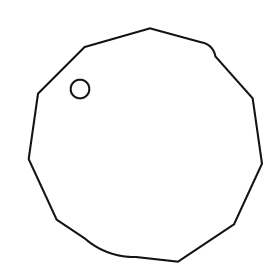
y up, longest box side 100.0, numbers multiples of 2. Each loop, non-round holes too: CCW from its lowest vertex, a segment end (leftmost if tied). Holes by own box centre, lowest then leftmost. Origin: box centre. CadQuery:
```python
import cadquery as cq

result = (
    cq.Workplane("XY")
    .moveTo(14.0, -50.0)
    .lineTo(38.0, -34.0)
    .lineTo(50.0, -8.0)
    .lineTo(46.0, 20.0)
    .lineTo(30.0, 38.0)
    .threePointArc((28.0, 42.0), (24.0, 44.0))
    .lineTo(2.0, 50.0)
    .lineTo(-26.0, 42.0)
    .lineTo(-46.0, 22.0)
    .lineTo(-50.0, -6.0)
    .lineTo(-38.0, -32.0)
    .lineTo(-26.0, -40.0)
    .threePointArc((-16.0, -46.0), (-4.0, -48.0))
    .close()
    .moveTo(-28.0, 24.0)
    .circle(4.0)
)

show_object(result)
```